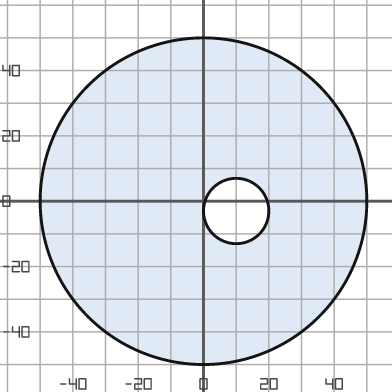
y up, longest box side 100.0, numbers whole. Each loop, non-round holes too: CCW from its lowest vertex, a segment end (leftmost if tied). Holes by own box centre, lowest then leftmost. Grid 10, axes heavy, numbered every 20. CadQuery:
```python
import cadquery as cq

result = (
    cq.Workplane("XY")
    .moveTo(0.0, 0.0)
    .circle(50.0)
    .moveTo(10.0, -3.0)
    .circle(10.0)
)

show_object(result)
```